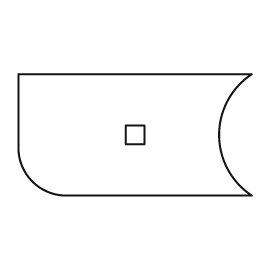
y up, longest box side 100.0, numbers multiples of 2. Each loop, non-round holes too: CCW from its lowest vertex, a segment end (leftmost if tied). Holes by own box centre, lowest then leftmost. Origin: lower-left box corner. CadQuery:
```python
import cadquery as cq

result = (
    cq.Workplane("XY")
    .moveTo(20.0, 0.0)
    .lineTo(100.0, 0.0)
    .threePointArc((86.0, 26.0), (100.0, 52.0))
    .lineTo(0.0, 52.0)
    .lineTo(0.0, 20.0)
    .threePointArc((6.0, 6.0), (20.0, 0.0))
    .close()
    .moveTo(46.0, 22.0)
    .lineTo(54.0, 22.0)
    .lineTo(54.0, 30.0)
    .lineTo(46.0, 30.0)
    .close()
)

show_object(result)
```